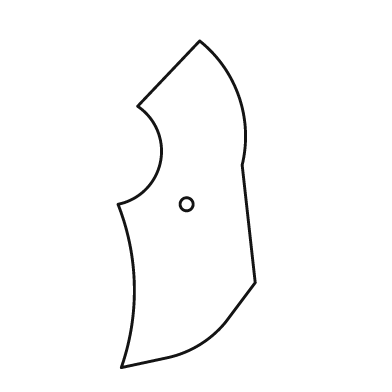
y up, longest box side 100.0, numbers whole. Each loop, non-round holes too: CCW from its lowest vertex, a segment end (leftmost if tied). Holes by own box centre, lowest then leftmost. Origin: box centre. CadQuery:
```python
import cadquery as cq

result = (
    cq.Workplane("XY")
    .moveTo(-20.0, -50.0)
    .lineTo(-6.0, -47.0)
    .threePointArc((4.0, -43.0), (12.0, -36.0))
    .lineTo(21.0, -24.0)
    .lineTo(17.0, 12.0)
    .threePointArc((16.0, 33.0), (4.0, 50.0))
    .lineTo(-15.0, 30.0)
    .threePointArc((-8.0, 13.0), (-21.0, 0.0))
    .threePointArc((-16.0, -25.0), (-20.0, -50.0))
    .close()
    .moveTo(0.0, 0.0)
    .circle(2.0)
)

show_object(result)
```